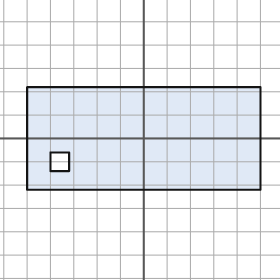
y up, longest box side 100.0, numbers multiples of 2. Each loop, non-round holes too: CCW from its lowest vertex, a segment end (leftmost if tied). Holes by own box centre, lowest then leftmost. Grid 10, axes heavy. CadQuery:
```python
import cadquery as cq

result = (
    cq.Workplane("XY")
    .moveTo(-50.0, -22.0)
    .lineTo(50.0, -22.0)
    .lineTo(50.0, 22.0)
    .lineTo(-50.0, 22.0)
    .close()
    .moveTo(-40.0, -14.0)
    .lineTo(-32.0, -14.0)
    .lineTo(-32.0, -6.0)
    .lineTo(-40.0, -6.0)
    .close()
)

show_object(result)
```